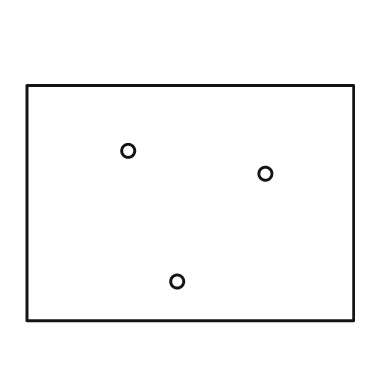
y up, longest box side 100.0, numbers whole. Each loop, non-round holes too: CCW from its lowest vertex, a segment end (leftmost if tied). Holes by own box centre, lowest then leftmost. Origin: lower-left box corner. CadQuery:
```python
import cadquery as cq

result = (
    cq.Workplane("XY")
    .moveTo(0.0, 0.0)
    .lineTo(100.0, 0.0)
    .lineTo(100.0, 72.0)
    .lineTo(0.0, 72.0)
    .close()
    .moveTo(46.0, 12.0)
    .circle(2.0)
    .moveTo(73.0, 45.0)
    .circle(2.0)
    .moveTo(31.0, 52.0)
    .circle(2.0)
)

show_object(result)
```